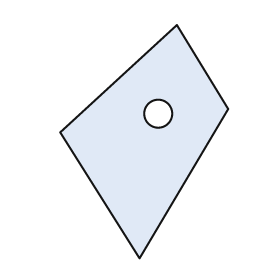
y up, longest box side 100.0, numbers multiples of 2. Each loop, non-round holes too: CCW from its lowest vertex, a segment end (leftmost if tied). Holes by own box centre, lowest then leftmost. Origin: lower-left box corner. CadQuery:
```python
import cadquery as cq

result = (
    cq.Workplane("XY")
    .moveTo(34.0, 0.0)
    .lineTo(72.0, 64.0)
    .lineTo(50.0, 100.0)
    .lineTo(0.0, 54.0)
    .close()
    .moveTo(42.0, 62.0)
    .circle(6.0)
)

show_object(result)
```